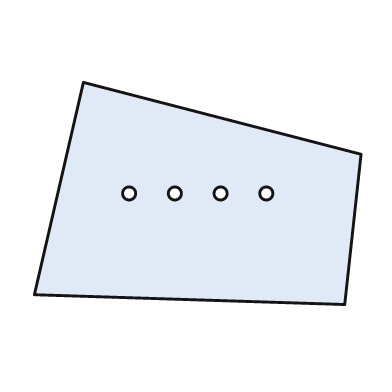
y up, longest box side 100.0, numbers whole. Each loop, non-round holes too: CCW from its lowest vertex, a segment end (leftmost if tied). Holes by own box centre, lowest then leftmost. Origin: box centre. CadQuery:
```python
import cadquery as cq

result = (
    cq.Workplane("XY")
    .moveTo(45.0, -34.0)
    .lineTo(50.0, 12.0)
    .lineTo(-35.0, 34.0)
    .lineTo(-50.0, -31.0)
    .close()
    .moveTo(-21.0, 0.0)
    .circle(2.0)
    .moveTo(-7.0, 0.0)
    .circle(2.0)
    .moveTo(7.0, 0.0)
    .circle(2.0)
    .moveTo(21.0, 0.0)
    .circle(2.0)
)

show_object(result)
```